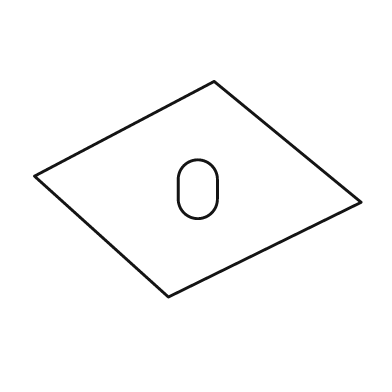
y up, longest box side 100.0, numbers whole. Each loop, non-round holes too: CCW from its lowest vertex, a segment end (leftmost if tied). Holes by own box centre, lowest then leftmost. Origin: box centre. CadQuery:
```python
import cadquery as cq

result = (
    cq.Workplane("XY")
    .moveTo(-9.0, -33.0)
    .lineTo(50.0, -4.0)
    .lineTo(5.0, 33.0)
    .lineTo(-50.0, 4.0)
    .close()
    .moveTo(-6.0, -3.0)
    .threePointArc((0.0, -9.0), (6.0, -3.0))
    .lineTo(6.0, 3.0)
    .threePointArc((0.0, 9.0), (-6.0, 3.0))
    .close()
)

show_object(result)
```